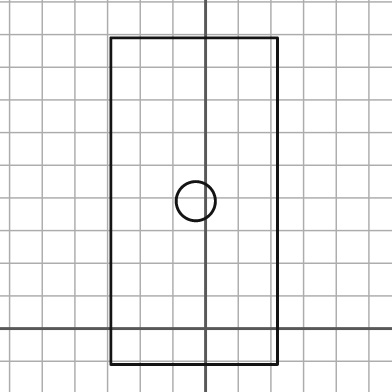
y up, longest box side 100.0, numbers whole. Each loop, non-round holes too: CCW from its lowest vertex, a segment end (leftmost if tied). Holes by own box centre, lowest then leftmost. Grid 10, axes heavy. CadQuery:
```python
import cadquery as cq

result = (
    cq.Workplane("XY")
    .moveTo(-29.0, -11.0)
    .lineTo(22.0, -11.0)
    .lineTo(22.0, 89.0)
    .lineTo(-29.0, 89.0)
    .close()
    .moveTo(-3.0, 39.0)
    .circle(6.0)
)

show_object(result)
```